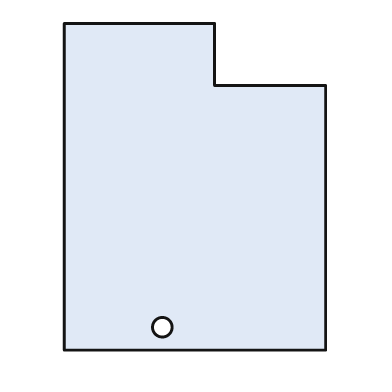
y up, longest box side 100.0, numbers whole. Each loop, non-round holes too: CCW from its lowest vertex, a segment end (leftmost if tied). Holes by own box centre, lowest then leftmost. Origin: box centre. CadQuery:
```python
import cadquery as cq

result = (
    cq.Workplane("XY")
    .moveTo(-40.0, -50.0)
    .lineTo(40.0, -50.0)
    .lineTo(40.0, 31.0)
    .lineTo(6.0, 31.0)
    .lineTo(6.0, 50.0)
    .lineTo(-40.0, 50.0)
    .close()
    .moveTo(-10.0, -43.0)
    .circle(3.0)
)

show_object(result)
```